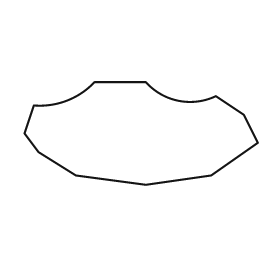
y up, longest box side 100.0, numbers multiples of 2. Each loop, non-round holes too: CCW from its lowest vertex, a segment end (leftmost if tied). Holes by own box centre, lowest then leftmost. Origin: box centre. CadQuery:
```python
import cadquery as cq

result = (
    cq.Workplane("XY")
    .moveTo(2.0, -22.0)
    .lineTo(30.0, -18.0)
    .lineTo(50.0, -4.0)
    .lineTo(44.0, 8.0)
    .lineTo(32.0, 16.0)
    .threePointArc((16.0, 14.0), (2.0, 22.0))
    .lineTo(-20.0, 22.0)
    .threePointArc((-32.0, 14.0), (-46.0, 12.0))
    .lineTo(-50.0, 0.0)
    .lineTo(-44.0, -8.0)
    .lineTo(-28.0, -18.0)
    .close()
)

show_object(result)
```